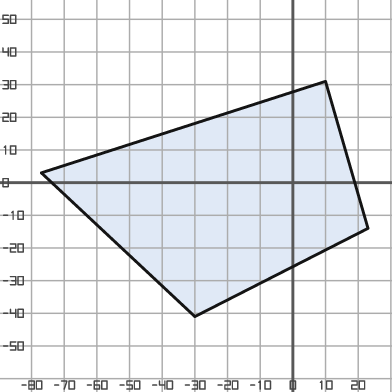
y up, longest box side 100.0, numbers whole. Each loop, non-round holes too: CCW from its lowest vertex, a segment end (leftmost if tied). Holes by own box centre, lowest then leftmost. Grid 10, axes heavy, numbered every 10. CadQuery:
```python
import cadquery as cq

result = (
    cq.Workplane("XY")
    .moveTo(-30.0, -41.0)
    .lineTo(23.0, -14.0)
    .lineTo(10.0, 31.0)
    .lineTo(-77.0, 3.0)
    .close()
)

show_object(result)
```